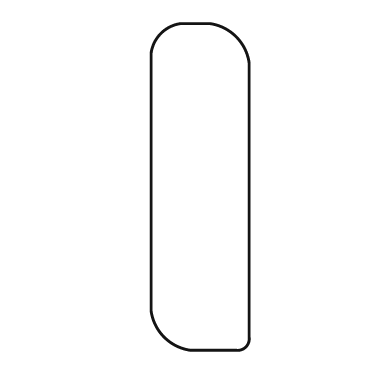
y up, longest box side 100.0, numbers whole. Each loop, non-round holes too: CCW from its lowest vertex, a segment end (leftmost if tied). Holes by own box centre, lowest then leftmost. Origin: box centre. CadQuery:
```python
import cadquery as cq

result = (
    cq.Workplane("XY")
    .moveTo(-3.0, -50.0)
    .lineTo(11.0, -50.0)
    .threePointArc((14.0, -49.0), (15.0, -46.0))
    .lineTo(15.0, 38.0)
    .threePointArc((11.0, 46.0), (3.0, 50.0))
    .lineTo(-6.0, 50.0)
    .threePointArc((-12.0, 47.0), (-15.0, 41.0))
    .lineTo(-15.0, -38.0)
    .threePointArc((-11.0, -46.0), (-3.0, -50.0))
    .close()
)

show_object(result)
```